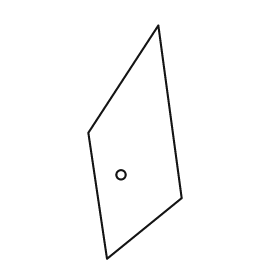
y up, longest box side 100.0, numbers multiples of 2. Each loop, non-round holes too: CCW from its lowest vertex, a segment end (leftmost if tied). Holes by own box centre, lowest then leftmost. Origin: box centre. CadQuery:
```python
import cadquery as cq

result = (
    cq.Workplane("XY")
    .moveTo(-12.0, -50.0)
    .lineTo(20.0, -24.0)
    .lineTo(10.0, 50.0)
    .lineTo(-20.0, 4.0)
    .close()
    .moveTo(-6.0, -14.0)
    .circle(2.0)
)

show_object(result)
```